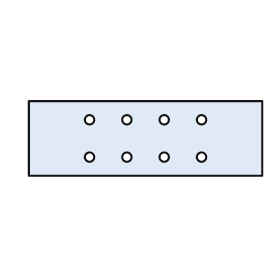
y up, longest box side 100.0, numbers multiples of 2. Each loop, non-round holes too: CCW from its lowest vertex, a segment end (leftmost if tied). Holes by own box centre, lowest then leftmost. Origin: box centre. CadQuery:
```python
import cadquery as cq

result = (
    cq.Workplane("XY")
    .moveTo(-50.0, -16.0)
    .lineTo(50.0, -16.0)
    .lineTo(50.0, 16.0)
    .lineTo(-50.0, 16.0)
    .close()
    .moveTo(-24.0, -8.0)
    .circle(2.0)
    .moveTo(-8.0, -8.0)
    .circle(2.0)
    .moveTo(8.0, -8.0)
    .circle(2.0)
    .moveTo(24.0, -8.0)
    .circle(2.0)
    .moveTo(-24.0, 8.0)
    .circle(2.0)
    .moveTo(-8.0, 8.0)
    .circle(2.0)
    .moveTo(8.0, 8.0)
    .circle(2.0)
    .moveTo(24.0, 8.0)
    .circle(2.0)
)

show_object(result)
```